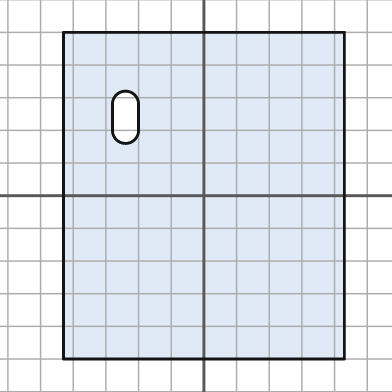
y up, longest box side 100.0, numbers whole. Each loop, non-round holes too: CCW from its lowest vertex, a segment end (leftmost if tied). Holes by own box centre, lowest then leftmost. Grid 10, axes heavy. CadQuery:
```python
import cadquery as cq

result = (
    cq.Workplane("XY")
    .moveTo(-43.0, -50.0)
    .lineTo(43.0, -50.0)
    .lineTo(43.0, 50.0)
    .lineTo(-43.0, 50.0)
    .close()
    .moveTo(-28.0, 20.0)
    .threePointArc((-24.0, 16.0), (-20.0, 20.0))
    .lineTo(-20.0, 28.0)
    .threePointArc((-24.0, 32.0), (-28.0, 28.0))
    .close()
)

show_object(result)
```